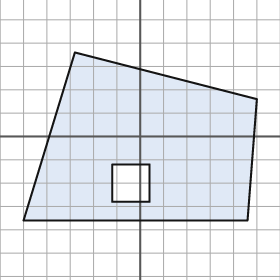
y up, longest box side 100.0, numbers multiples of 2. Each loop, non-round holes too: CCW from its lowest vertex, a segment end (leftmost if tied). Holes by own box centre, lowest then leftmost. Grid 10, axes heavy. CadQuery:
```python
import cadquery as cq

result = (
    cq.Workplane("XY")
    .moveTo(-50.0, -36.0)
    .lineTo(46.0, -36.0)
    .lineTo(50.0, 16.0)
    .lineTo(-28.0, 36.0)
    .close()
    .moveTo(-12.0, -28.0)
    .lineTo(4.0, -28.0)
    .lineTo(4.0, -12.0)
    .lineTo(-12.0, -12.0)
    .close()
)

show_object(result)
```